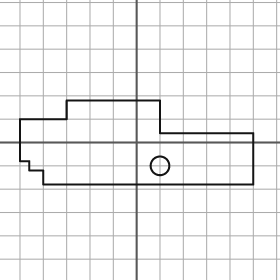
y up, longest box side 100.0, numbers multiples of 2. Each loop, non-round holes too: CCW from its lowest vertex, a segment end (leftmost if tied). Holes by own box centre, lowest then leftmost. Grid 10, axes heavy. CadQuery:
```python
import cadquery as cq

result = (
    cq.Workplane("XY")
    .moveTo(-40.0, -18.0)
    .lineTo(50.0, -18.0)
    .lineTo(50.0, 4.0)
    .lineTo(10.0, 4.0)
    .lineTo(10.0, 18.0)
    .lineTo(-30.0, 18.0)
    .lineTo(-30.0, 10.0)
    .lineTo(-50.0, 10.0)
    .lineTo(-50.0, -8.0)
    .lineTo(-46.0, -8.0)
    .lineTo(-46.0, -12.0)
    .lineTo(-40.0, -12.0)
    .close()
    .moveTo(10.0, -10.0)
    .circle(4.0)
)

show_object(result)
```